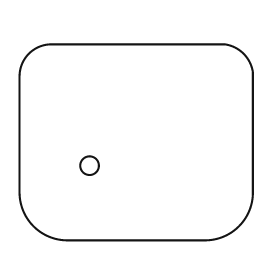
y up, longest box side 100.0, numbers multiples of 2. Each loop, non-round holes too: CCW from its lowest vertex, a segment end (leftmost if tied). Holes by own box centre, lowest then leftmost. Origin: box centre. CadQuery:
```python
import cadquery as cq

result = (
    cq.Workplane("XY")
    .moveTo(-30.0, -42.0)
    .lineTo(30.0, -42.0)
    .threePointArc((44.0, -36.0), (50.0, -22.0))
    .lineTo(50.0, 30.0)
    .threePointArc((46.0, 38.0), (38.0, 42.0))
    .lineTo(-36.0, 42.0)
    .threePointArc((-46.0, 38.0), (-50.0, 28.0))
    .lineTo(-50.0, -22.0)
    .threePointArc((-44.0, -36.0), (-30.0, -42.0))
    .close()
    .moveTo(-20.0, -10.0)
    .circle(4.0)
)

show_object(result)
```